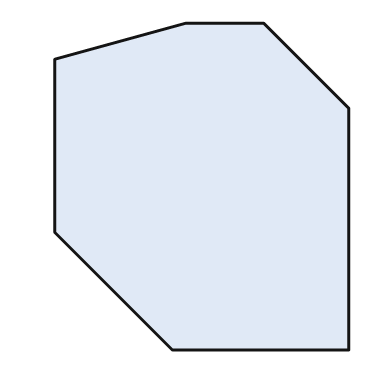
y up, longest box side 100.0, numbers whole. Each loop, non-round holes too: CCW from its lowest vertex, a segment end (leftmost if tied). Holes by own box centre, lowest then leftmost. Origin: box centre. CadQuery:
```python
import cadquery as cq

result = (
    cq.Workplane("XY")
    .moveTo(-9.0, -50.0)
    .lineTo(45.0, -50.0)
    .lineTo(45.0, 24.0)
    .lineTo(19.0, 50.0)
    .lineTo(-5.0, 50.0)
    .lineTo(-45.0, 39.0)
    .lineTo(-45.0, -14.0)
    .close()
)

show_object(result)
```